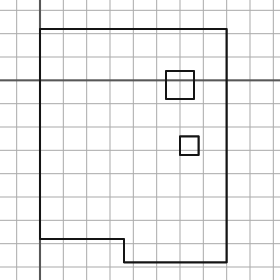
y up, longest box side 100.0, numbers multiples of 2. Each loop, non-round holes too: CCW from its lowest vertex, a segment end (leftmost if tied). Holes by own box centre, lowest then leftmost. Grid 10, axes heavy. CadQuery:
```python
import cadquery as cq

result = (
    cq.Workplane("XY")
    .moveTo(36.0, -78.0)
    .lineTo(80.0, -78.0)
    .lineTo(80.0, 22.0)
    .lineTo(0.0, 22.0)
    .lineTo(0.0, -68.0)
    .lineTo(36.0, -68.0)
    .close()
    .moveTo(60.0, -32.0)
    .lineTo(68.0, -32.0)
    .lineTo(68.0, -24.0)
    .lineTo(60.0, -24.0)
    .close()
    .moveTo(54.0, -8.0)
    .lineTo(66.0, -8.0)
    .lineTo(66.0, 4.0)
    .lineTo(54.0, 4.0)
    .close()
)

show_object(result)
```